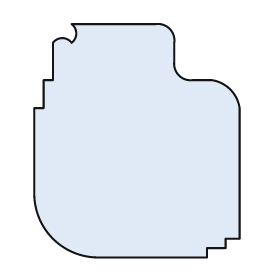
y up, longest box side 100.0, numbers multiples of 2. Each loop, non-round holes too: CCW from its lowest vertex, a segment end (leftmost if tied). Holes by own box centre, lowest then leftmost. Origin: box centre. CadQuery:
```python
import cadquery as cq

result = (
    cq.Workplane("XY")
    .moveTo(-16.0, -50.0)
    .lineTo(30.0, -50.0)
    .lineTo(30.0, -46.0)
    .lineTo(38.0, -46.0)
    .lineTo(38.0, -42.0)
    .lineTo(44.0, -42.0)
    .lineTo(44.0, 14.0)
    .threePointArc((40.0, 22.0), (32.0, 26.0))
    .lineTo(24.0, 26.0)
    .threePointArc((18.0, 28.0), (16.0, 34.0))
    .lineTo(16.0, 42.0)
    .threePointArc((14.0, 48.0), (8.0, 50.0))
    .lineTo(-28.0, 50.0)
    .threePointArc((-26.0, 46.0), (-28.0, 42.0))
    .threePointArc((-32.0, 44.0), (-36.0, 42.0))
    .lineTo(-36.0, 26.0)
    .lineTo(-40.0, 26.0)
    .lineTo(-40.0, 14.0)
    .lineTo(-44.0, 14.0)
    .lineTo(-44.0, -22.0)
    .threePointArc((-36.0, -42.0), (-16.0, -50.0))
    .close()
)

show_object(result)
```